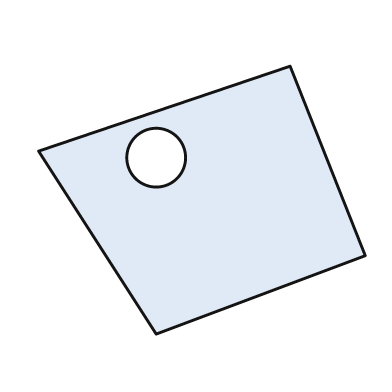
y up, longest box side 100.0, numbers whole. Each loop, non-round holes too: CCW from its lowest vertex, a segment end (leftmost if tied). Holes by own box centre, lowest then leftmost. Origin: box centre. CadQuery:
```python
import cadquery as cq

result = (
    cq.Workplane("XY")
    .moveTo(-14.0, -41.0)
    .lineTo(50.0, -17.0)
    .lineTo(27.0, 41.0)
    .lineTo(-50.0, 15.0)
    .close()
    .moveTo(-14.0, 13.0)
    .circle(9.0)
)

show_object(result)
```